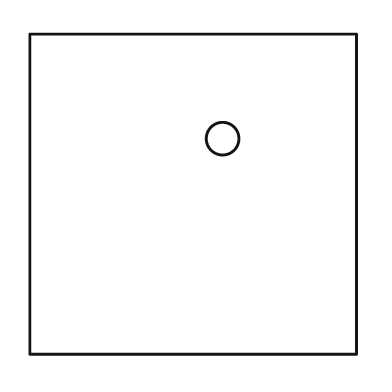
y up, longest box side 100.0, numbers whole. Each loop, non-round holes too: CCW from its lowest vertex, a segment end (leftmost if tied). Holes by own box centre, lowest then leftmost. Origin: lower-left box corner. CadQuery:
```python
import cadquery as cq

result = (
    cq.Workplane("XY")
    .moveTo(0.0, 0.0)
    .lineTo(100.0, 0.0)
    .lineTo(100.0, 98.0)
    .lineTo(0.0, 98.0)
    .close()
    .moveTo(59.0, 66.0)
    .circle(5.0)
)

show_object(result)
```